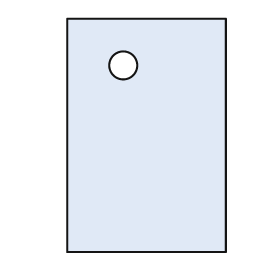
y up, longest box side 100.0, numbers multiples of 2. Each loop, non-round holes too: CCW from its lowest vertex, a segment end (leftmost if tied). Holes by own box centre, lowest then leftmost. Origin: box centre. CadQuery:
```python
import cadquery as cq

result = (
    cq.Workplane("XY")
    .moveTo(-34.0, -50.0)
    .lineTo(34.0, -50.0)
    .lineTo(34.0, 50.0)
    .lineTo(-34.0, 50.0)
    .close()
    .moveTo(-10.0, 30.0)
    .circle(6.0)
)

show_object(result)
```